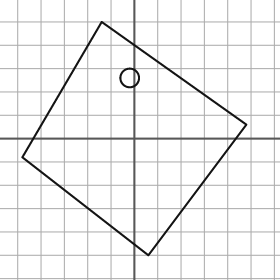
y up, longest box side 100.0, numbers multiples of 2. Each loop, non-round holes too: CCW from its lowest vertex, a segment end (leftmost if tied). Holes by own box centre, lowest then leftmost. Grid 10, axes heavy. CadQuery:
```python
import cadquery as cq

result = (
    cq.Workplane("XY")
    .moveTo(6.0, -50.0)
    .lineTo(48.0, 6.0)
    .lineTo(-14.0, 50.0)
    .lineTo(-48.0, -8.0)
    .close()
    .moveTo(-2.0, 26.0)
    .circle(4.0)
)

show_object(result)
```